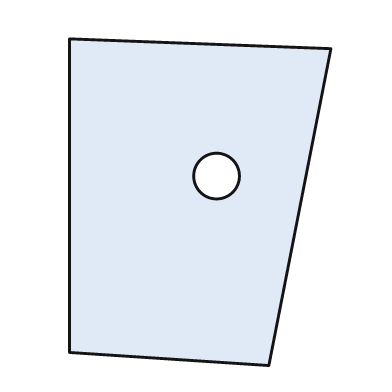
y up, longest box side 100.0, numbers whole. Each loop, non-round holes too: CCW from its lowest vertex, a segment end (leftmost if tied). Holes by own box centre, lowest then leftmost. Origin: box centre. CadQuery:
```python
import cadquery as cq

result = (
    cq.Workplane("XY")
    .moveTo(21.0, -50.0)
    .lineTo(40.0, 47.0)
    .lineTo(-40.0, 50.0)
    .lineTo(-40.0, -46.0)
    .close()
    .moveTo(5.0, 8.0)
    .circle(7.0)
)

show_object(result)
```